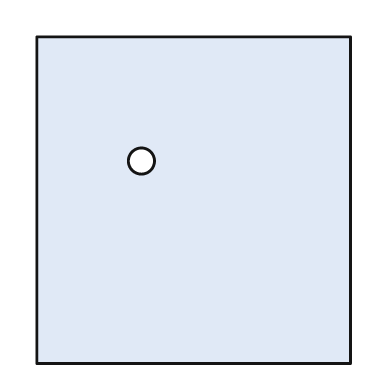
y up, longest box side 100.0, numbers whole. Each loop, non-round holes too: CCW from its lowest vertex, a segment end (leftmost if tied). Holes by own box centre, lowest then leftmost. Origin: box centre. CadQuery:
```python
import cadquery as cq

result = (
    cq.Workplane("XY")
    .moveTo(-48.0, -50.0)
    .lineTo(48.0, -50.0)
    .lineTo(48.0, 50.0)
    .lineTo(-48.0, 50.0)
    .close()
    .moveTo(-16.0, 12.0)
    .circle(4.0)
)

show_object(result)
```